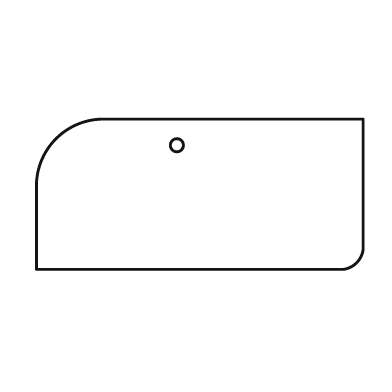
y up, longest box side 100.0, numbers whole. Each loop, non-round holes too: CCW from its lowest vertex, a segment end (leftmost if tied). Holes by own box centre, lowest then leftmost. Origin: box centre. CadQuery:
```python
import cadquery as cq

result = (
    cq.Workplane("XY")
    .moveTo(-50.0, -23.0)
    .lineTo(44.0, -23.0)
    .threePointArc((48.0, -21.0), (50.0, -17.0))
    .lineTo(50.0, 23.0)
    .lineTo(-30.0, 23.0)
    .threePointArc((-44.0, 17.0), (-50.0, 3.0))
    .close()
    .moveTo(-7.0, 15.0)
    .circle(2.0)
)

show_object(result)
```